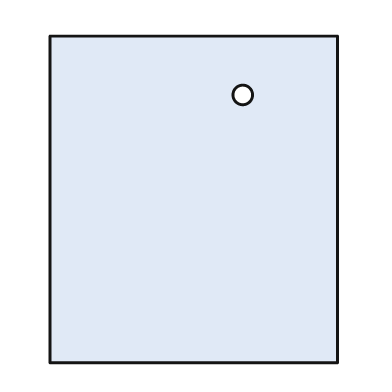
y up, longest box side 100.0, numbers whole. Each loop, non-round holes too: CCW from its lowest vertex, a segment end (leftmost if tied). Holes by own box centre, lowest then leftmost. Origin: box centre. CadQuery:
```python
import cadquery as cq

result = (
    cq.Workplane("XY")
    .moveTo(-44.0, -50.0)
    .lineTo(44.0, -50.0)
    .lineTo(44.0, 50.0)
    .lineTo(-44.0, 50.0)
    .close()
    .moveTo(15.0, 32.0)
    .circle(3.0)
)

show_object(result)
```